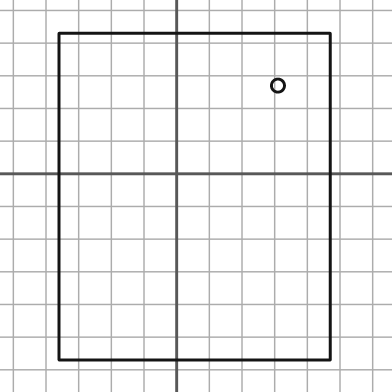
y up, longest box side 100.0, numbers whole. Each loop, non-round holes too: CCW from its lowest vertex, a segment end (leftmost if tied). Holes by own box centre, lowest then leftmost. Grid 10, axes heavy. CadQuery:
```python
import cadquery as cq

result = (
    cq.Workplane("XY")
    .moveTo(-36.0, -57.0)
    .lineTo(47.0, -57.0)
    .lineTo(47.0, 43.0)
    .lineTo(-36.0, 43.0)
    .close()
    .moveTo(31.0, 27.0)
    .circle(2.0)
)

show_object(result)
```